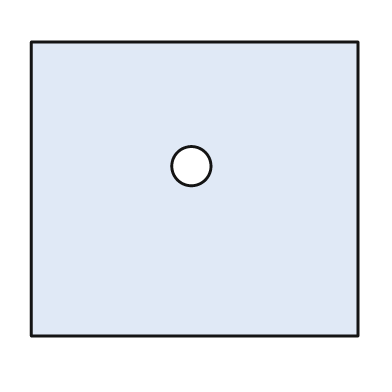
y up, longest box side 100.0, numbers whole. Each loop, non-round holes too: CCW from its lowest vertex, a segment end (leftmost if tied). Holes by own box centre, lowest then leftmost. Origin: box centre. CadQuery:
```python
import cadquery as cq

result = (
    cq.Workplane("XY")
    .moveTo(-50.0, -45.0)
    .lineTo(50.0, -45.0)
    .lineTo(50.0, 45.0)
    .lineTo(-50.0, 45.0)
    .close()
    .moveTo(-1.0, 7.0)
    .circle(6.0)
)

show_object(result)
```